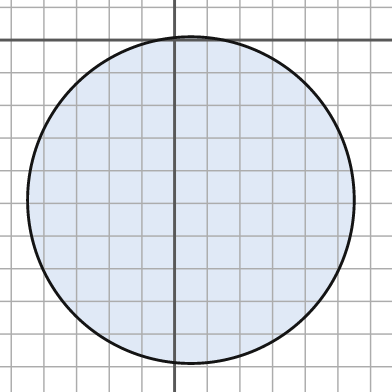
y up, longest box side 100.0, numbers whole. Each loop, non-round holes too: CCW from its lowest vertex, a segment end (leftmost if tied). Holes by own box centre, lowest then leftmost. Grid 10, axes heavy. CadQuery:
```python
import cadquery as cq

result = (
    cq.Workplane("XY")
    .moveTo(5.0, -49.0)
    .circle(50.0)
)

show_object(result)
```